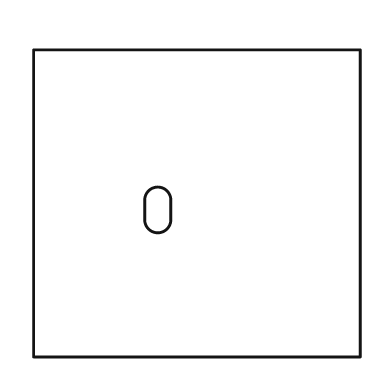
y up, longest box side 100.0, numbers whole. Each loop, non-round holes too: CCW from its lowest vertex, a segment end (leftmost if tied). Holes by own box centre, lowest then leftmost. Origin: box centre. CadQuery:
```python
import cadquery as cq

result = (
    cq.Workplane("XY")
    .moveTo(-50.0, -47.0)
    .lineTo(50.0, -47.0)
    .lineTo(50.0, 47.0)
    .lineTo(-50.0, 47.0)
    .close()
    .moveTo(-16.0, -5.0)
    .threePointArc((-12.0, -9.0), (-8.0, -5.0))
    .lineTo(-8.0, 1.0)
    .threePointArc((-12.0, 5.0), (-16.0, 1.0))
    .close()
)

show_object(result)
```